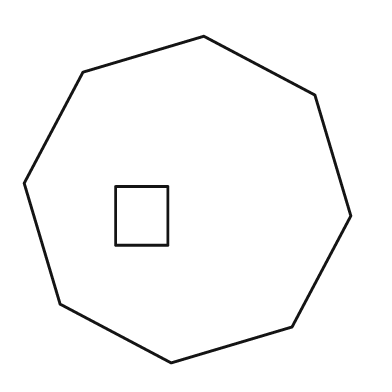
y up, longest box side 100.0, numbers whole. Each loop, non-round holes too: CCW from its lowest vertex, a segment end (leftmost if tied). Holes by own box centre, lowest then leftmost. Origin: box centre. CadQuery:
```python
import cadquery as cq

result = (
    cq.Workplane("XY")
    .moveTo(-5.0, -50.0)
    .lineTo(32.0, -39.0)
    .lineTo(50.0, -5.0)
    .lineTo(39.0, 32.0)
    .lineTo(5.0, 50.0)
    .lineTo(-32.0, 39.0)
    .lineTo(-50.0, 5.0)
    .lineTo(-39.0, -32.0)
    .close()
    .moveTo(-22.0, -14.0)
    .lineTo(-6.0, -14.0)
    .lineTo(-6.0, 4.0)
    .lineTo(-22.0, 4.0)
    .close()
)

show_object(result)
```